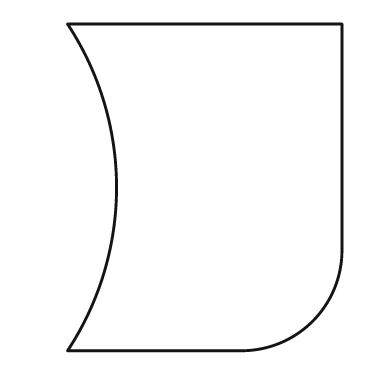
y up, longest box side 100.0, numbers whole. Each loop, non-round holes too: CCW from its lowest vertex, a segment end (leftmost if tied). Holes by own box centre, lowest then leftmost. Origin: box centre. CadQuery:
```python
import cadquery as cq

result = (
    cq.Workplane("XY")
    .moveTo(-42.0, -50.0)
    .lineTo(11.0, -50.0)
    .threePointArc((33.0, -41.0), (42.0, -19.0))
    .lineTo(42.0, 50.0)
    .lineTo(-42.0, 50.0)
    .threePointArc((-27.0, 0.0), (-42.0, -50.0))
    .close()
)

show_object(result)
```